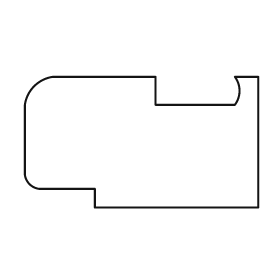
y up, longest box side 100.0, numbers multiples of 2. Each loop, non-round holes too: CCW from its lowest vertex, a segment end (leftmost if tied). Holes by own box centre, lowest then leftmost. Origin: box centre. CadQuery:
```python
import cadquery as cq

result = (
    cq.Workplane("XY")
    .moveTo(-20.0, -28.0)
    .lineTo(50.0, -28.0)
    .lineTo(50.0, 28.0)
    .lineTo(40.0, 28.0)
    .threePointArc((42.0, 22.0), (40.0, 16.0))
    .lineTo(6.0, 16.0)
    .lineTo(6.0, 28.0)
    .lineTo(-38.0, 28.0)
    .threePointArc((-46.0, 24.0), (-50.0, 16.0))
    .lineTo(-50.0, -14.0)
    .threePointArc((-48.0, -18.0), (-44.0, -20.0))
    .lineTo(-20.0, -20.0)
    .close()
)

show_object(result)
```